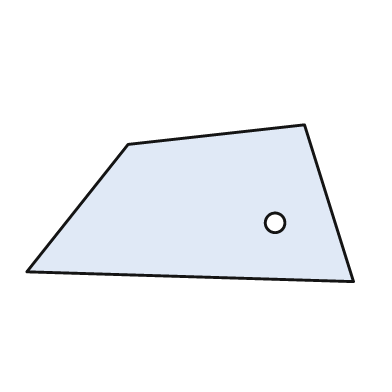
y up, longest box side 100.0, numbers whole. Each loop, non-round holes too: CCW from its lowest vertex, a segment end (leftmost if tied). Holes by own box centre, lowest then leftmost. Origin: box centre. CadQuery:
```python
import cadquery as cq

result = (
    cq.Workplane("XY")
    .moveTo(50.0, -24.0)
    .lineTo(35.0, 24.0)
    .lineTo(-19.0, 18.0)
    .lineTo(-50.0, -21.0)
    .close()
    .moveTo(26.0, -6.0)
    .circle(3.0)
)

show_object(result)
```